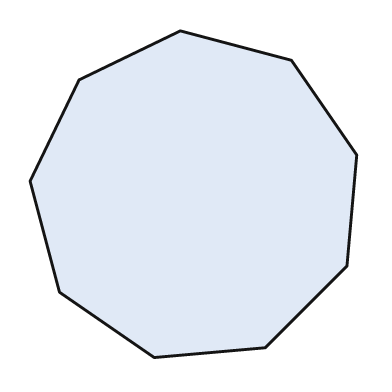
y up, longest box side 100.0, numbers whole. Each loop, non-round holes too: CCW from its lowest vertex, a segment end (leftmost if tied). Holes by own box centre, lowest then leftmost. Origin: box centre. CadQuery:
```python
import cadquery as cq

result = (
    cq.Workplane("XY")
    .moveTo(-12.0, -50.0)
    .lineTo(22.0, -47.0)
    .lineTo(47.0, -22.0)
    .lineTo(50.0, 12.0)
    .lineTo(30.0, 41.0)
    .lineTo(-4.0, 50.0)
    .lineTo(-35.0, 35.0)
    .lineTo(-50.0, 4.0)
    .lineTo(-41.0, -30.0)
    .close()
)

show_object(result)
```